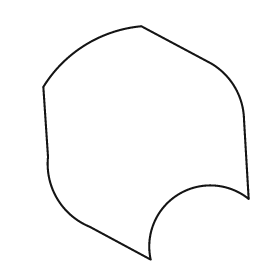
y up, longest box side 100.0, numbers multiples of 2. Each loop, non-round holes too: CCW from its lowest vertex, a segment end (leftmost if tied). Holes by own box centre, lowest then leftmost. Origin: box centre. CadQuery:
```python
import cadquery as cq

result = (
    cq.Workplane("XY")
    .moveTo(2.0, -50.0)
    .threePointArc((14.0, -22.0), (44.0, -24.0))
    .lineTo(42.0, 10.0)
    .threePointArc((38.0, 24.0), (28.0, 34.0))
    .lineTo(-2.0, 50.0)
    .threePointArc((-26.0, 42.0), (-44.0, 24.0))
    .lineTo(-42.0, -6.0)
    .threePointArc((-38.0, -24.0), (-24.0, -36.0))
    .close()
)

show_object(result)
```